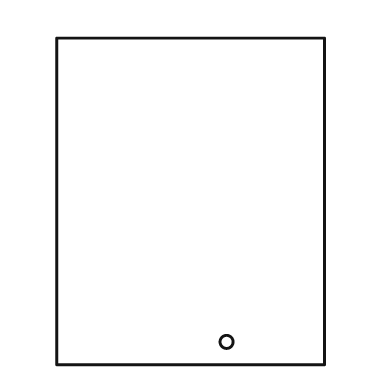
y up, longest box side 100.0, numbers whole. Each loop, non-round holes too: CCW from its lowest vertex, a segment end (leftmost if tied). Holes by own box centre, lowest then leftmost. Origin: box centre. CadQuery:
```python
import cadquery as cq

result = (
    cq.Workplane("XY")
    .moveTo(-41.0, -50.0)
    .lineTo(41.0, -50.0)
    .lineTo(41.0, 50.0)
    .lineTo(-41.0, 50.0)
    .close()
    .moveTo(11.0, -43.0)
    .circle(2.0)
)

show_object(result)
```